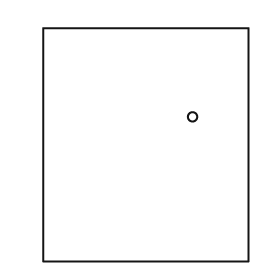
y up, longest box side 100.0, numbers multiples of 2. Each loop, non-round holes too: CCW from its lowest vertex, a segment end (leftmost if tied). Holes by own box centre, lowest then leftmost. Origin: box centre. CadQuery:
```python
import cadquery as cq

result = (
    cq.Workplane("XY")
    .moveTo(-44.0, -50.0)
    .lineTo(44.0, -50.0)
    .lineTo(44.0, 50.0)
    .lineTo(-44.0, 50.0)
    .close()
    .moveTo(20.0, 12.0)
    .circle(2.0)
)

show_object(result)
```